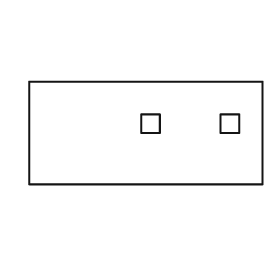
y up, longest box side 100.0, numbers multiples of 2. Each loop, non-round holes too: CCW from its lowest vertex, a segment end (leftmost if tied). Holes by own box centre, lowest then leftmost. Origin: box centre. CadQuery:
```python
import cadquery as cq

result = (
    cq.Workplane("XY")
    .moveTo(-50.0, -22.0)
    .lineTo(50.0, -22.0)
    .lineTo(50.0, 22.0)
    .lineTo(-50.0, 22.0)
    .close()
    .moveTo(-2.0, 0.0)
    .lineTo(6.0, 0.0)
    .lineTo(6.0, 8.0)
    .lineTo(-2.0, 8.0)
    .close()
    .moveTo(32.0, 0.0)
    .lineTo(40.0, 0.0)
    .lineTo(40.0, 8.0)
    .lineTo(32.0, 8.0)
    .close()
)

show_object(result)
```